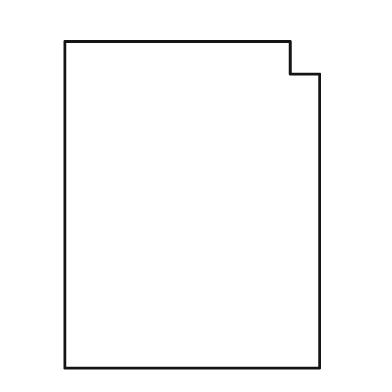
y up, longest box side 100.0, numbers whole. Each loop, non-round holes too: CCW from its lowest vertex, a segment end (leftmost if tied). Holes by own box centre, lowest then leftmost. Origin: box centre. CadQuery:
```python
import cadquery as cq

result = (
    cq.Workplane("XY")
    .moveTo(-39.0, -50.0)
    .lineTo(39.0, -50.0)
    .lineTo(39.0, 40.0)
    .lineTo(30.0, 40.0)
    .lineTo(30.0, 50.0)
    .lineTo(-39.0, 50.0)
    .close()
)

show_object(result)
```